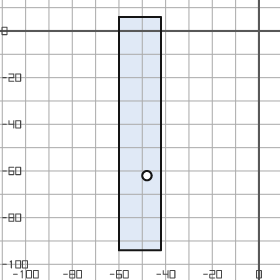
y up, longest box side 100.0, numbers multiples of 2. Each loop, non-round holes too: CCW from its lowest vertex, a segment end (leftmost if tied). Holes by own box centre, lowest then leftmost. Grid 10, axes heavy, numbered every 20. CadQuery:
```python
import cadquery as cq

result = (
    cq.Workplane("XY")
    .moveTo(-60.0, -94.0)
    .lineTo(-42.0, -94.0)
    .lineTo(-42.0, 6.0)
    .lineTo(-60.0, 6.0)
    .close()
    .moveTo(-48.0, -62.0)
    .circle(2.0)
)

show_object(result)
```